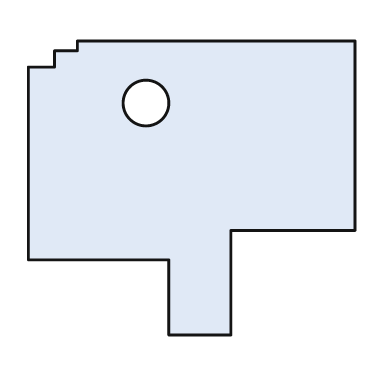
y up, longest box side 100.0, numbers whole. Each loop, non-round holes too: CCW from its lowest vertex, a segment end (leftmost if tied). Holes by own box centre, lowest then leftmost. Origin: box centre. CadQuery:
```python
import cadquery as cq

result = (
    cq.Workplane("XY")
    .moveTo(-7.0, -45.0)
    .lineTo(12.0, -45.0)
    .lineTo(12.0, -13.0)
    .lineTo(50.0, -13.0)
    .lineTo(50.0, 45.0)
    .lineTo(-35.0, 45.0)
    .lineTo(-35.0, 42.0)
    .lineTo(-42.0, 42.0)
    .lineTo(-42.0, 37.0)
    .lineTo(-50.0, 37.0)
    .lineTo(-50.0, -22.0)
    .lineTo(-7.0, -22.0)
    .close()
    .moveTo(-14.0, 26.0)
    .circle(7.0)
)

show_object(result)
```